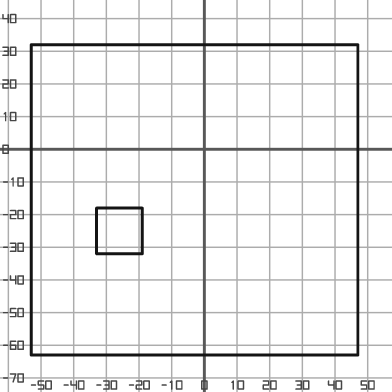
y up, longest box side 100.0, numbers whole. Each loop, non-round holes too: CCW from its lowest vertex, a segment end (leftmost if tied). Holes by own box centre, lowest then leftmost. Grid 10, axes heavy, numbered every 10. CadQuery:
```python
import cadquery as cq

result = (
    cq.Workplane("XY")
    .moveTo(-53.0, -63.0)
    .lineTo(47.0, -63.0)
    .lineTo(47.0, 32.0)
    .lineTo(-53.0, 32.0)
    .close()
    .moveTo(-33.0, -32.0)
    .lineTo(-19.0, -32.0)
    .lineTo(-19.0, -18.0)
    .lineTo(-33.0, -18.0)
    .close()
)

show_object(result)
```